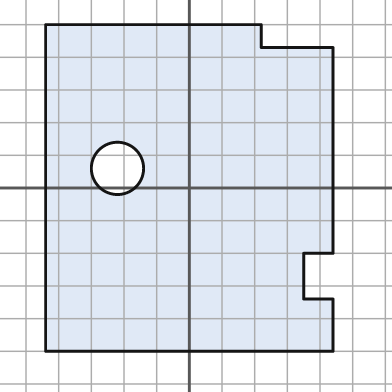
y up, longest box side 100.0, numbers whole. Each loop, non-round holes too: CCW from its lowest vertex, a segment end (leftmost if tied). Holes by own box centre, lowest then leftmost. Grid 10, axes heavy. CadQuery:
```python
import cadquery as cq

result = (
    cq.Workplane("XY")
    .moveTo(-44.0, -50.0)
    .lineTo(44.0, -50.0)
    .lineTo(44.0, -34.0)
    .lineTo(35.0, -34.0)
    .lineTo(35.0, -20.0)
    .lineTo(44.0, -20.0)
    .lineTo(44.0, 43.0)
    .lineTo(22.0, 43.0)
    .lineTo(22.0, 50.0)
    .lineTo(-44.0, 50.0)
    .close()
    .moveTo(-22.0, 6.0)
    .circle(8.0)
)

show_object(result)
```